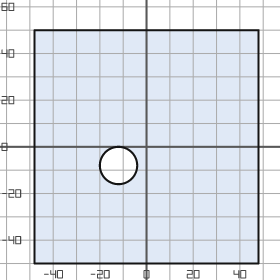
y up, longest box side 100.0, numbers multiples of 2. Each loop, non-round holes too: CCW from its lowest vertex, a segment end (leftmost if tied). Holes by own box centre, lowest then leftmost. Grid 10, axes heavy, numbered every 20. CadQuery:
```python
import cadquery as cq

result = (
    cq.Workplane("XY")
    .moveTo(-48.0, -50.0)
    .lineTo(48.0, -50.0)
    .lineTo(48.0, 50.0)
    .lineTo(-48.0, 50.0)
    .close()
    .moveTo(-12.0, -8.0)
    .circle(8.0)
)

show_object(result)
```